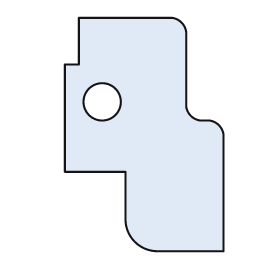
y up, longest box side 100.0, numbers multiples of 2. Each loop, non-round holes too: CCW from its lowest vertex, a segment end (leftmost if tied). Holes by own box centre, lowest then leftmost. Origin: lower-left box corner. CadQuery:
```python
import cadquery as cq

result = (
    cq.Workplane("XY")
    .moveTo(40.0, 0.0)
    .lineTo(68.0, 0.0)
    .lineTo(68.0, 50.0)
    .threePointArc((66.0, 54.0), (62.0, 56.0))
    .lineTo(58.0, 56.0)
    .threePointArc((54.0, 58.0), (52.0, 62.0))
    .lineTo(52.0, 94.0)
    .threePointArc((50.0, 98.0), (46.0, 100.0))
    .lineTo(6.0, 100.0)
    .lineTo(6.0, 80.0)
    .lineTo(0.0, 80.0)
    .lineTo(0.0, 34.0)
    .lineTo(26.0, 34.0)
    .lineTo(26.0, 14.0)
    .threePointArc((30.0, 4.0), (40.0, 0.0))
    .close()
    .moveTo(16.0, 64.0)
    .circle(8.0)
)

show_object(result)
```